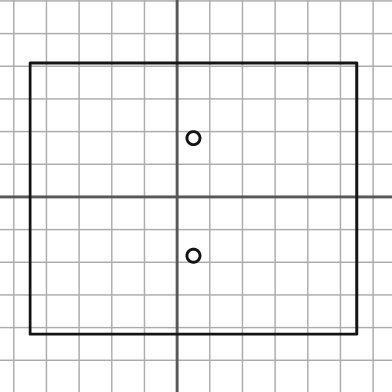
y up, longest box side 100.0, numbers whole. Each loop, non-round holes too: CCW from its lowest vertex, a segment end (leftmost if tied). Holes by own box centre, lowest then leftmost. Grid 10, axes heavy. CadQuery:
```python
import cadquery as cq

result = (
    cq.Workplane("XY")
    .moveTo(-45.0, -42.0)
    .lineTo(55.0, -42.0)
    .lineTo(55.0, 41.0)
    .lineTo(-45.0, 41.0)
    .close()
    .moveTo(5.0, -18.0)
    .circle(2.0)
    .moveTo(5.0, 18.0)
    .circle(2.0)
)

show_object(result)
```